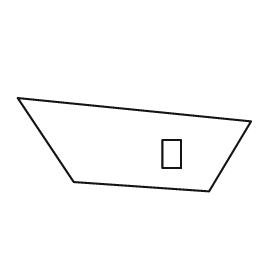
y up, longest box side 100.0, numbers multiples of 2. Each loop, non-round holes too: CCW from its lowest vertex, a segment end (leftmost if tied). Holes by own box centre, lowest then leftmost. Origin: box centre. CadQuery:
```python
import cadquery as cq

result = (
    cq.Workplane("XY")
    .moveTo(32.0, -20.0)
    .lineTo(50.0, 10.0)
    .lineTo(-50.0, 20.0)
    .lineTo(-26.0, -16.0)
    .close()
    .moveTo(12.0, -10.0)
    .lineTo(20.0, -10.0)
    .lineTo(20.0, 2.0)
    .lineTo(12.0, 2.0)
    .close()
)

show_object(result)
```